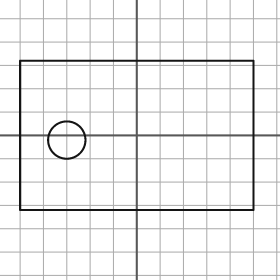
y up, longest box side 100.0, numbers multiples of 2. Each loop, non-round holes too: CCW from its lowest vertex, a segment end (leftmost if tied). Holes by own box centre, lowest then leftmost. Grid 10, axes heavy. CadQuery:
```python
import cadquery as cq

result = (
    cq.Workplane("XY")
    .moveTo(-50.0, -32.0)
    .lineTo(50.0, -32.0)
    .lineTo(50.0, 32.0)
    .lineTo(-50.0, 32.0)
    .close()
    .moveTo(-30.0, -2.0)
    .circle(8.0)
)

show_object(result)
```